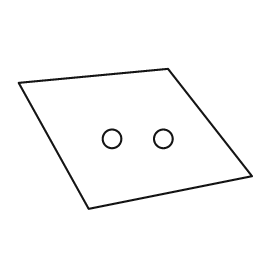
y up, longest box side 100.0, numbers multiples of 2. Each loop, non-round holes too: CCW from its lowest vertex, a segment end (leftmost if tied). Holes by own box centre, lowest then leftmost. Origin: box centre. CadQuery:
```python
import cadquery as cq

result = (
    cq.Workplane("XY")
    .moveTo(-20.0, -30.0)
    .lineTo(50.0, -16.0)
    .lineTo(14.0, 30.0)
    .lineTo(-50.0, 24.0)
    .close()
    .moveTo(-10.0, 0.0)
    .circle(4.0)
    .moveTo(12.0, 0.0)
    .circle(4.0)
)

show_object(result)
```